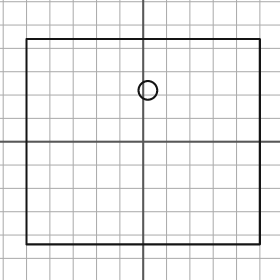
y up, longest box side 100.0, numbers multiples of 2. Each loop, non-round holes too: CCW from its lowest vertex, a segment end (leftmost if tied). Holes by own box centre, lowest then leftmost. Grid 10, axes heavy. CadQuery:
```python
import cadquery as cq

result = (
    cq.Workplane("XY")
    .moveTo(-50.0, -44.0)
    .lineTo(50.0, -44.0)
    .lineTo(50.0, 44.0)
    .lineTo(-50.0, 44.0)
    .close()
    .moveTo(2.0, 22.0)
    .circle(4.0)
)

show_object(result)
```